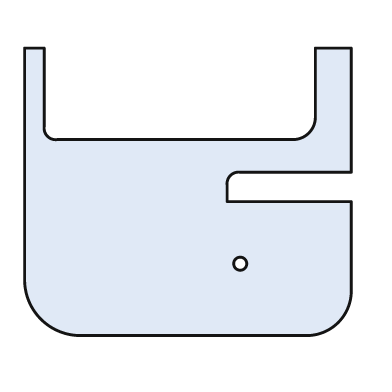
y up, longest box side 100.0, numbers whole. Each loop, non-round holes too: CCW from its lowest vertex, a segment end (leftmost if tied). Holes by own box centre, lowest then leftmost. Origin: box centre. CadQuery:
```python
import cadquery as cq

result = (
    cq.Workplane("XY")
    .moveTo(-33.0, -44.0)
    .lineTo(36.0, -44.0)
    .threePointArc((46.0, -40.0), (50.0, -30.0))
    .lineTo(50.0, -3.0)
    .lineTo(12.0, -3.0)
    .lineTo(12.0, 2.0)
    .threePointArc((13.0, 5.0), (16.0, 6.0))
    .lineTo(50.0, 6.0)
    .lineTo(50.0, 44.0)
    .lineTo(39.0, 44.0)
    .lineTo(39.0, 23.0)
    .threePointArc((37.0, 18.0), (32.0, 16.0))
    .lineTo(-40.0, 16.0)
    .threePointArc((-43.0, 17.0), (-44.0, 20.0))
    .lineTo(-44.0, 44.0)
    .lineTo(-50.0, 44.0)
    .lineTo(-50.0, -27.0)
    .threePointArc((-45.0, -39.0), (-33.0, -44.0))
    .close()
    .moveTo(16.0, -22.0)
    .circle(2.0)
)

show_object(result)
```